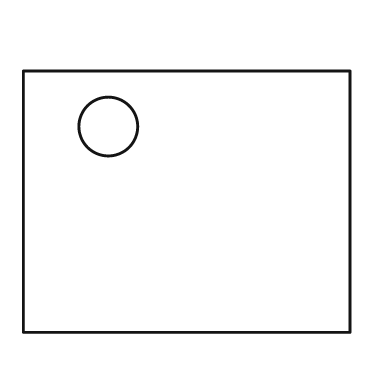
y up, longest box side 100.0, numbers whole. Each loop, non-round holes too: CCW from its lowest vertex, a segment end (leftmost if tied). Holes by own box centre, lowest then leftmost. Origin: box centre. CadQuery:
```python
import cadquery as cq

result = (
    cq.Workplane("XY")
    .moveTo(-50.0, -40.0)
    .lineTo(50.0, -40.0)
    .lineTo(50.0, 40.0)
    .lineTo(-50.0, 40.0)
    .close()
    .moveTo(-24.0, 23.0)
    .circle(9.0)
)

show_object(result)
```